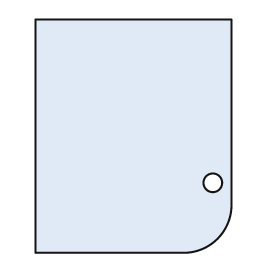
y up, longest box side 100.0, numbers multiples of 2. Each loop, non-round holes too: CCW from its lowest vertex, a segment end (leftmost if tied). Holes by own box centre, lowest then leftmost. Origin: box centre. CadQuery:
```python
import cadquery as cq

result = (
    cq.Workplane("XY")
    .moveTo(-42.0, -50.0)
    .lineTo(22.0, -50.0)
    .threePointArc((36.0, -44.0), (42.0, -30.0))
    .lineTo(42.0, 50.0)
    .lineTo(-42.0, 50.0)
    .close()
    .moveTo(34.0, -20.0)
    .circle(4.0)
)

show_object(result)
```